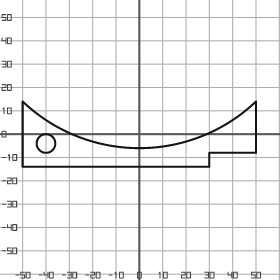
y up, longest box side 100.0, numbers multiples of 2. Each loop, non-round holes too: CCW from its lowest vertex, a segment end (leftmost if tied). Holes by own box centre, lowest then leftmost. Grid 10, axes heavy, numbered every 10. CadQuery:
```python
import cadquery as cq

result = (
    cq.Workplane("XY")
    .moveTo(-50.0, -14.0)
    .lineTo(30.0, -14.0)
    .lineTo(30.0, -8.0)
    .lineTo(50.0, -8.0)
    .lineTo(50.0, 14.0)
    .threePointArc((0.0, -6.0), (-50.0, 14.0))
    .close()
    .moveTo(-40.0, -4.0)
    .circle(4.0)
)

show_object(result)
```